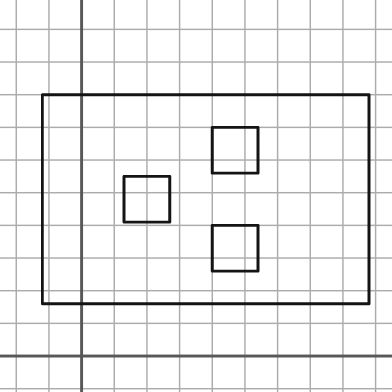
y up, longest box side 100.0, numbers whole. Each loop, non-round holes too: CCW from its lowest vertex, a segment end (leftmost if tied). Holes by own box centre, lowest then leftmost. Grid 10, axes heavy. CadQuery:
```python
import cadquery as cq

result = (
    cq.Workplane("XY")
    .moveTo(-12.0, 16.0)
    .lineTo(88.0, 16.0)
    .lineTo(88.0, 80.0)
    .lineTo(-12.0, 80.0)
    .close()
    .moveTo(40.0, 26.0)
    .lineTo(54.0, 26.0)
    .lineTo(54.0, 40.0)
    .lineTo(40.0, 40.0)
    .close()
    .moveTo(13.0, 41.0)
    .lineTo(27.0, 41.0)
    .lineTo(27.0, 55.0)
    .lineTo(13.0, 55.0)
    .close()
    .moveTo(40.0, 56.0)
    .lineTo(54.0, 56.0)
    .lineTo(54.0, 70.0)
    .lineTo(40.0, 70.0)
    .close()
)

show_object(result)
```